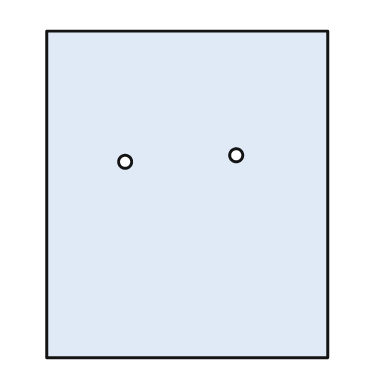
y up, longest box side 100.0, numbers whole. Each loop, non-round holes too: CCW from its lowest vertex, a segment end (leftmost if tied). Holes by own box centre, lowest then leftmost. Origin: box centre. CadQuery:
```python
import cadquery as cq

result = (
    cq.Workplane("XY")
    .moveTo(-43.0, -50.0)
    .lineTo(43.0, -50.0)
    .lineTo(43.0, 50.0)
    .lineTo(-43.0, 50.0)
    .close()
    .moveTo(-19.0, 10.0)
    .circle(2.0)
    .moveTo(15.0, 12.0)
    .circle(2.0)
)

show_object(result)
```